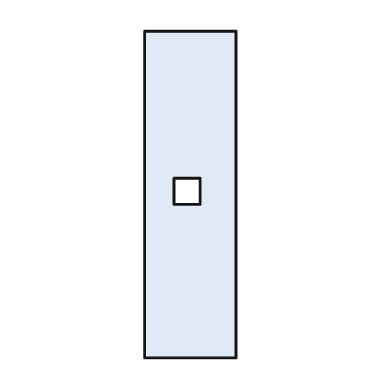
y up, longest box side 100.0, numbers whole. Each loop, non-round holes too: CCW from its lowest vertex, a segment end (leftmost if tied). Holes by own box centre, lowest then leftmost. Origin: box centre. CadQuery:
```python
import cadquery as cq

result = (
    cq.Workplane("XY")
    .moveTo(-14.0, -50.0)
    .lineTo(14.0, -50.0)
    .lineTo(14.0, 50.0)
    .lineTo(-14.0, 50.0)
    .close()
    .moveTo(-5.0, -3.0)
    .lineTo(3.0, -3.0)
    .lineTo(3.0, 5.0)
    .lineTo(-5.0, 5.0)
    .close()
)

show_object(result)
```